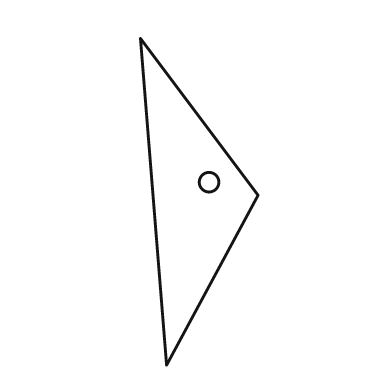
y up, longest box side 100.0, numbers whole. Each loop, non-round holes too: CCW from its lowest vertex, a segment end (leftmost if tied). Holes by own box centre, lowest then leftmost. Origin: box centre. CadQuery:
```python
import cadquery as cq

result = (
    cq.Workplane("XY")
    .moveTo(-10.0, -50.0)
    .lineTo(18.0, 2.0)
    .lineTo(-18.0, 50.0)
    .close()
    .moveTo(3.0, 6.0)
    .circle(3.0)
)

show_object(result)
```